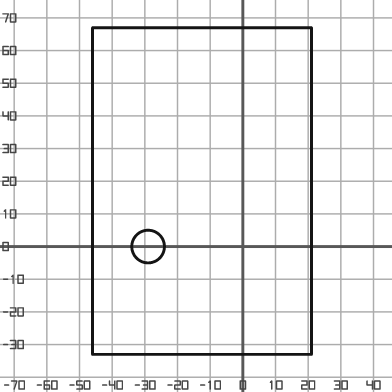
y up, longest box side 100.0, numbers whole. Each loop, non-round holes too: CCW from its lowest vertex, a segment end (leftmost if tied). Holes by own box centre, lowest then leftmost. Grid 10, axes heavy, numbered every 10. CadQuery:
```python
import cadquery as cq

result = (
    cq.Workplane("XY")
    .moveTo(-46.0, -33.0)
    .lineTo(21.0, -33.0)
    .lineTo(21.0, 67.0)
    .lineTo(-46.0, 67.0)
    .close()
    .moveTo(-29.0, 0.0)
    .circle(5.0)
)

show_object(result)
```